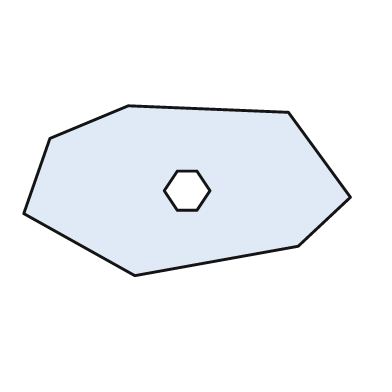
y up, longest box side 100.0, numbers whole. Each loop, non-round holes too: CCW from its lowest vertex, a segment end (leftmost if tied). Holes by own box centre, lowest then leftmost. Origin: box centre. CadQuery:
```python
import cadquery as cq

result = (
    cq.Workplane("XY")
    .moveTo(-16.0, -26.0)
    .lineTo(34.0, -17.0)
    .lineTo(50.0, -2.0)
    .lineTo(31.0, 24.0)
    .lineTo(-18.0, 26.0)
    .lineTo(-42.0, 16.0)
    .lineTo(-50.0, -7.0)
    .close()
    .moveTo(-3.0, -6.0)
    .lineTo(3.0, -6.0)
    .lineTo(7.0, 0.0)
    .lineTo(3.0, 6.0)
    .lineTo(-3.0, 6.0)
    .lineTo(-7.0, 0.0)
    .close()
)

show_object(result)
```